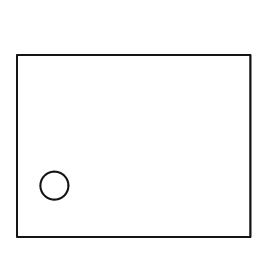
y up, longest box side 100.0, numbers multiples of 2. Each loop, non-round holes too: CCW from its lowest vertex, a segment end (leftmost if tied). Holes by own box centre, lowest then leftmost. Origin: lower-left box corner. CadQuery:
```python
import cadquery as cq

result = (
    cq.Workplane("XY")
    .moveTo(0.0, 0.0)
    .lineTo(100.0, 0.0)
    .lineTo(100.0, 78.0)
    .lineTo(0.0, 78.0)
    .close()
    .moveTo(16.0, 22.0)
    .circle(6.0)
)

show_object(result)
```